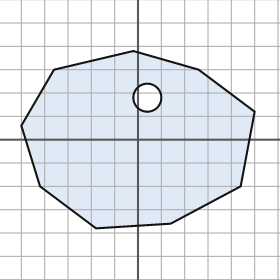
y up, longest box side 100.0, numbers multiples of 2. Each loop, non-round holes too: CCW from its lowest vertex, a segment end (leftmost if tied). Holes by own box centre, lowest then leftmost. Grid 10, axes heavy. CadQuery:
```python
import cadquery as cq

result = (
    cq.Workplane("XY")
    .moveTo(-18.0, -38.0)
    .lineTo(14.0, -36.0)
    .lineTo(44.0, -20.0)
    .lineTo(50.0, 12.0)
    .lineTo(26.0, 30.0)
    .lineTo(-2.0, 38.0)
    .lineTo(-36.0, 30.0)
    .lineTo(-50.0, 6.0)
    .lineTo(-42.0, -20.0)
    .close()
    .moveTo(4.0, 18.0)
    .circle(6.0)
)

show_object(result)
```